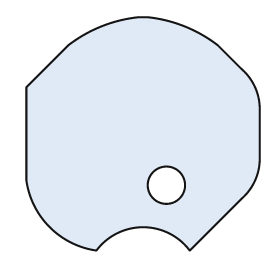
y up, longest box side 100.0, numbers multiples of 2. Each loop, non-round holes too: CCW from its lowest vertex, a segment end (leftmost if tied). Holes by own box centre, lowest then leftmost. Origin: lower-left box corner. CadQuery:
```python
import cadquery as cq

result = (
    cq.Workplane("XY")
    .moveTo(30.0, 0.0)
    .threePointArc((50.0, 10.0), (70.0, 0.0))
    .lineTo(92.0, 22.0)
    .threePointArc((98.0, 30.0), (100.0, 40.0))
    .lineTo(100.0, 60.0)
    .threePointArc((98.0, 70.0), (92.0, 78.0))
    .lineTo(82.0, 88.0)
    .threePointArc((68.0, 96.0), (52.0, 100.0))
    .lineTo(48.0, 100.0)
    .threePointArc((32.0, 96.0), (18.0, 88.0))
    .lineTo(0.0, 70.0)
    .lineTo(0.0, 30.0)
    .threePointArc((10.0, 10.0), (30.0, 0.0))
    .close()
    .moveTo(60.0, 28.0)
    .circle(8.0)
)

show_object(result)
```